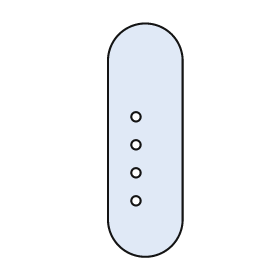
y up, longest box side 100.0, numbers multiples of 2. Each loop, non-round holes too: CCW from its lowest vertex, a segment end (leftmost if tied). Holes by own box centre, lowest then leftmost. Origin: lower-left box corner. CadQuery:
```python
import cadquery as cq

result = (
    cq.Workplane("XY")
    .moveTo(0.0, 16.0)
    .threePointArc((16.0, 0.0), (32.0, 16.0))
    .lineTo(32.0, 84.0)
    .threePointArc((16.0, 100.0), (0.0, 84.0))
    .close()
    .moveTo(12.0, 24.0)
    .circle(2.0)
    .moveTo(12.0, 36.0)
    .circle(2.0)
    .moveTo(12.0, 48.0)
    .circle(2.0)
    .moveTo(12.0, 60.0)
    .circle(2.0)
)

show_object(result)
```